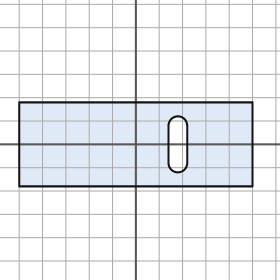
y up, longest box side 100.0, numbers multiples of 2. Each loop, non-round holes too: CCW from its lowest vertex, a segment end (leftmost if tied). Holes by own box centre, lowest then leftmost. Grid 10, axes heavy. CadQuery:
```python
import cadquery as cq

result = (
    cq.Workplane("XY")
    .moveTo(-50.0, -18.0)
    .lineTo(50.0, -18.0)
    .lineTo(50.0, 18.0)
    .lineTo(-50.0, 18.0)
    .close()
    .moveTo(14.0, -8.0)
    .threePointArc((18.0, -12.0), (22.0, -8.0))
    .lineTo(22.0, 8.0)
    .threePointArc((18.0, 12.0), (14.0, 8.0))
    .close()
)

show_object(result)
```